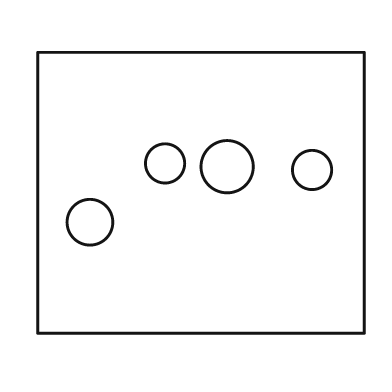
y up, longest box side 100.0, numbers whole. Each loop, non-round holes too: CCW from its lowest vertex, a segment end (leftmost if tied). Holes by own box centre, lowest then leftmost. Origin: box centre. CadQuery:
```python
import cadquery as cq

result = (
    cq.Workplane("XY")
    .moveTo(-50.0, -43.0)
    .lineTo(50.0, -43.0)
    .lineTo(50.0, 43.0)
    .lineTo(-50.0, 43.0)
    .close()
    .moveTo(-34.0, -9.0)
    .circle(7.0)
    .moveTo(34.0, 7.0)
    .circle(6.0)
    .moveTo(8.0, 8.0)
    .circle(8.0)
    .moveTo(-11.0, 9.0)
    .circle(6.0)
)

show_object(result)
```